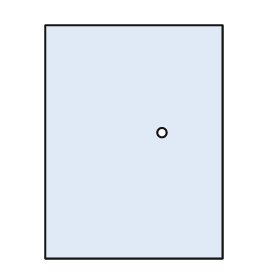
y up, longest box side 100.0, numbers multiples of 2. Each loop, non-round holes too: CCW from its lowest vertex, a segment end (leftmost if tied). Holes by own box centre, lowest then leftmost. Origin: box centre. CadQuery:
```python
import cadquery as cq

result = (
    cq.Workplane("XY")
    .moveTo(-38.0, -50.0)
    .lineTo(38.0, -50.0)
    .lineTo(38.0, 50.0)
    .lineTo(-38.0, 50.0)
    .close()
    .moveTo(12.0, 4.0)
    .circle(2.0)
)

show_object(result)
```